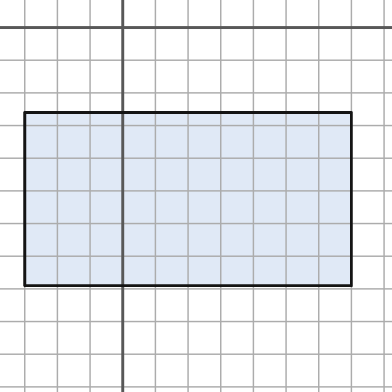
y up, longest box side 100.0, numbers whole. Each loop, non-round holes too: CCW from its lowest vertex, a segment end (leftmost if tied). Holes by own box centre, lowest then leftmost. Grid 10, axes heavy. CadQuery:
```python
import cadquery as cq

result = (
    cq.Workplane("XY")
    .moveTo(-30.0, -79.0)
    .lineTo(70.0, -79.0)
    .lineTo(70.0, -26.0)
    .lineTo(-30.0, -26.0)
    .close()
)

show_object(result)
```